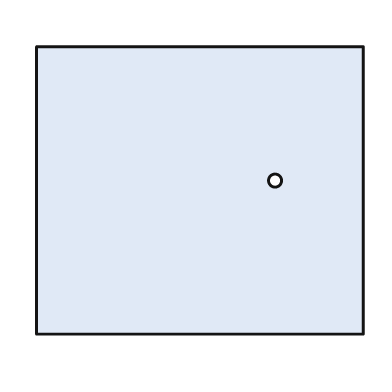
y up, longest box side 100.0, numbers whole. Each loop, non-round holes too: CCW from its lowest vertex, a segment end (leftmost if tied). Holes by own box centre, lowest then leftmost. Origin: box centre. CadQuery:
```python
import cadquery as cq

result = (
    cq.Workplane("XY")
    .moveTo(-50.0, -44.0)
    .lineTo(50.0, -44.0)
    .lineTo(50.0, 44.0)
    .lineTo(-50.0, 44.0)
    .close()
    .moveTo(23.0, 3.0)
    .circle(2.0)
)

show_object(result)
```